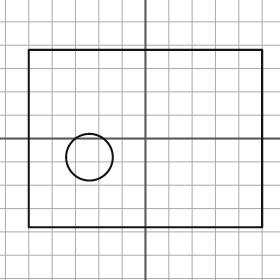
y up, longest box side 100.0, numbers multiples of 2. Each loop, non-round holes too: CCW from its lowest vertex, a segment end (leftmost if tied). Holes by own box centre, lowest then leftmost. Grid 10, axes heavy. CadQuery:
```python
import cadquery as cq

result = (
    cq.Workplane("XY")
    .moveTo(-50.0, -38.0)
    .lineTo(50.0, -38.0)
    .lineTo(50.0, 38.0)
    .lineTo(-50.0, 38.0)
    .close()
    .moveTo(-24.0, -8.0)
    .circle(10.0)
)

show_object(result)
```